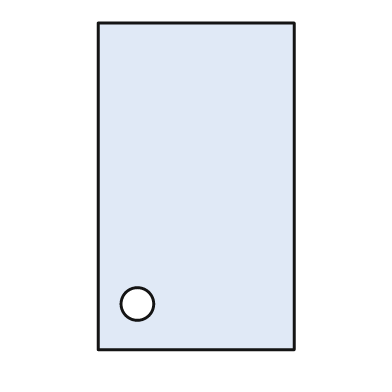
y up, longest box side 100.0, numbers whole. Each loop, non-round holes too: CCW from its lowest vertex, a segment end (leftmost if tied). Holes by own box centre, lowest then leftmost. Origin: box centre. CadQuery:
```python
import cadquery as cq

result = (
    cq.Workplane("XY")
    .moveTo(-30.0, -50.0)
    .lineTo(30.0, -50.0)
    .lineTo(30.0, 50.0)
    .lineTo(-30.0, 50.0)
    .close()
    .moveTo(-18.0, -36.0)
    .circle(5.0)
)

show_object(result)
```